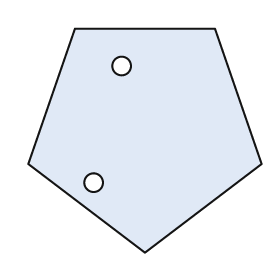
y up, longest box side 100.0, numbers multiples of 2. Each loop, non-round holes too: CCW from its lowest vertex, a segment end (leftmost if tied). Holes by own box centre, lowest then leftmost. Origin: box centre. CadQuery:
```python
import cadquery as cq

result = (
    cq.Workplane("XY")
    .moveTo(0.0, -48.0)
    .lineTo(50.0, -10.0)
    .lineTo(30.0, 48.0)
    .lineTo(-30.0, 48.0)
    .lineTo(-50.0, -10.0)
    .close()
    .moveTo(-22.0, -18.0)
    .circle(4.0)
    .moveTo(-10.0, 32.0)
    .circle(4.0)
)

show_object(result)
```